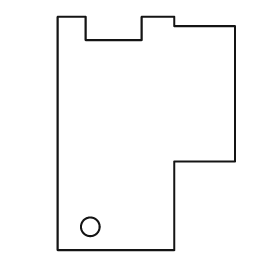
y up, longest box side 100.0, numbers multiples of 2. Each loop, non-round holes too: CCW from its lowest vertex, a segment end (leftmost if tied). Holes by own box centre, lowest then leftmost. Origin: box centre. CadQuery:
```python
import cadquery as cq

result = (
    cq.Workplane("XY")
    .moveTo(-38.0, -50.0)
    .lineTo(12.0, -50.0)
    .lineTo(12.0, -12.0)
    .lineTo(38.0, -12.0)
    .lineTo(38.0, 46.0)
    .lineTo(12.0, 46.0)
    .lineTo(12.0, 50.0)
    .lineTo(-2.0, 50.0)
    .lineTo(-2.0, 40.0)
    .lineTo(-26.0, 40.0)
    .lineTo(-26.0, 50.0)
    .lineTo(-38.0, 50.0)
    .close()
    .moveTo(-24.0, -40.0)
    .circle(4.0)
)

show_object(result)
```